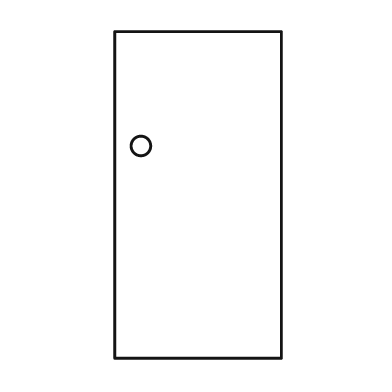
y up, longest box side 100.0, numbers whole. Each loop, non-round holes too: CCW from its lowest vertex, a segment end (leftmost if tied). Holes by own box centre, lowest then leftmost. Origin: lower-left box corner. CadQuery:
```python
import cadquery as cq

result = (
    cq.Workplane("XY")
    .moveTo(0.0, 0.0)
    .lineTo(51.0, 0.0)
    .lineTo(51.0, 100.0)
    .lineTo(0.0, 100.0)
    .close()
    .moveTo(8.0, 65.0)
    .circle(3.0)
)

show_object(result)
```